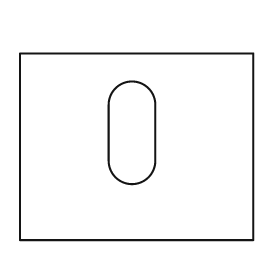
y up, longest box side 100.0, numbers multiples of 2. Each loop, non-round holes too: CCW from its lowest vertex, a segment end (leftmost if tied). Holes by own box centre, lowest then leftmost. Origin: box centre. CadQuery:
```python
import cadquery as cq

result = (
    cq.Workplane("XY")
    .moveTo(-50.0, -40.0)
    .lineTo(50.0, -40.0)
    .lineTo(50.0, 40.0)
    .lineTo(-50.0, 40.0)
    .close()
    .moveTo(-12.0, -6.0)
    .threePointArc((-2.0, -16.0), (8.0, -6.0))
    .lineTo(8.0, 18.0)
    .threePointArc((-2.0, 28.0), (-12.0, 18.0))
    .close()
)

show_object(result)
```